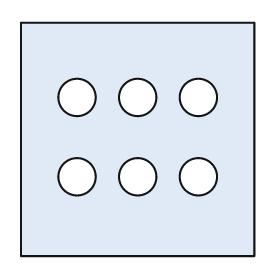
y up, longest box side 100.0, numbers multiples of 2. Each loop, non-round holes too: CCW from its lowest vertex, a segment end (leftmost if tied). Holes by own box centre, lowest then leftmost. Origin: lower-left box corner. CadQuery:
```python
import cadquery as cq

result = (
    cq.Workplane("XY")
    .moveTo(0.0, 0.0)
    .lineTo(100.0, 0.0)
    .lineTo(100.0, 100.0)
    .lineTo(0.0, 100.0)
    .close()
    .moveTo(24.0, 34.0)
    .circle(8.0)
    .moveTo(50.0, 34.0)
    .circle(8.0)
    .moveTo(76.0, 34.0)
    .circle(8.0)
    .moveTo(24.0, 68.0)
    .circle(8.0)
    .moveTo(50.0, 68.0)
    .circle(8.0)
    .moveTo(76.0, 68.0)
    .circle(8.0)
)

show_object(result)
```